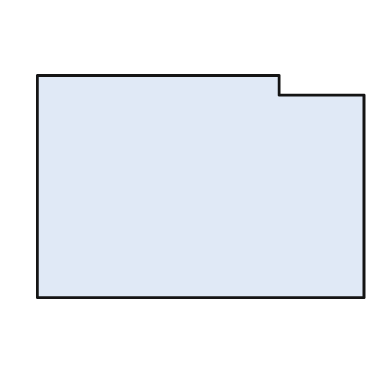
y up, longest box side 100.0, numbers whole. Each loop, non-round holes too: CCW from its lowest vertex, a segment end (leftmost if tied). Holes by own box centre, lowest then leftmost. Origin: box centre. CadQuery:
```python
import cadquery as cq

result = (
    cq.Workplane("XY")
    .moveTo(-50.0, -34.0)
    .lineTo(50.0, -34.0)
    .lineTo(50.0, 28.0)
    .lineTo(24.0, 28.0)
    .lineTo(24.0, 34.0)
    .lineTo(-50.0, 34.0)
    .close()
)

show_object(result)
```